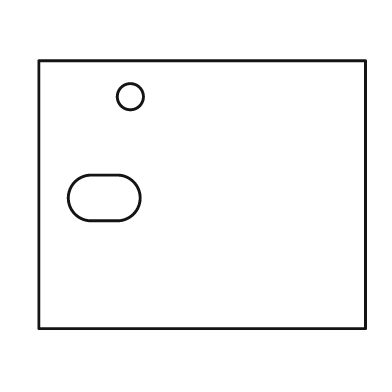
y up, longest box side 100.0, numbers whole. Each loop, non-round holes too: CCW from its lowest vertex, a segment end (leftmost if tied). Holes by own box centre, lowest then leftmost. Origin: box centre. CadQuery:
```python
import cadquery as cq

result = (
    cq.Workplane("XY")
    .moveTo(-50.0, -41.0)
    .lineTo(50.0, -41.0)
    .lineTo(50.0, 41.0)
    .lineTo(-50.0, 41.0)
    .close()
    .moveTo(-34.0, -8.0)
    .lineTo(-26.0, -8.0)
    .threePointArc((-19.0, -1.0), (-26.0, 6.0))
    .lineTo(-34.0, 6.0)
    .threePointArc((-41.0, -1.0), (-34.0, -8.0))
    .close()
    .moveTo(-22.0, 30.0)
    .circle(4.0)
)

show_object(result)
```